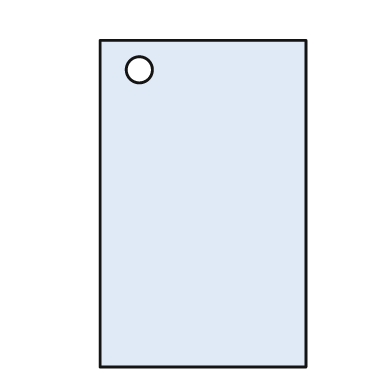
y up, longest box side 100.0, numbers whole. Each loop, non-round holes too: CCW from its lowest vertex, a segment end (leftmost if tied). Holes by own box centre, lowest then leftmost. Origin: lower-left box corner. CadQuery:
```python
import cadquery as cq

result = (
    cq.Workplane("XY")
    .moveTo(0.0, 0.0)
    .lineTo(63.0, 0.0)
    .lineTo(63.0, 100.0)
    .lineTo(0.0, 100.0)
    .close()
    .moveTo(12.0, 91.0)
    .circle(4.0)
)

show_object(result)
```